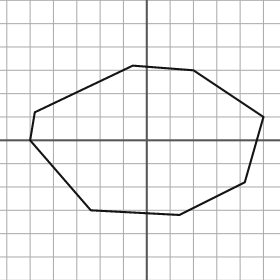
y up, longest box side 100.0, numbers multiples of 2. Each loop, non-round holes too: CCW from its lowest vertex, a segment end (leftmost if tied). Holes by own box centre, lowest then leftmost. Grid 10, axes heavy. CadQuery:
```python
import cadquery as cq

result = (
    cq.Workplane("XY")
    .moveTo(14.0, -32.0)
    .lineTo(42.0, -18.0)
    .lineTo(50.0, 10.0)
    .lineTo(20.0, 30.0)
    .lineTo(-6.0, 32.0)
    .lineTo(-48.0, 12.0)
    .lineTo(-50.0, 0.0)
    .lineTo(-24.0, -30.0)
    .close()
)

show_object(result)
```